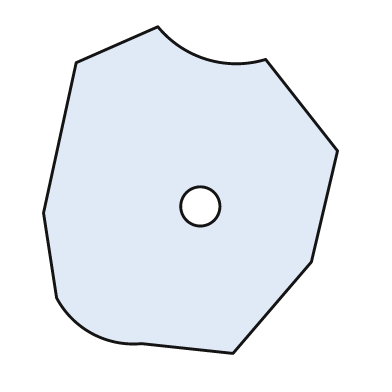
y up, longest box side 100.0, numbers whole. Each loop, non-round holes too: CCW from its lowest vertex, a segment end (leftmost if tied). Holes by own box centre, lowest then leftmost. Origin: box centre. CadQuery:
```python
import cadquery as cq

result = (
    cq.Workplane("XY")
    .moveTo(13.0, -50.0)
    .lineTo(37.0, -22.0)
    .lineTo(45.0, 12.0)
    .lineTo(23.0, 40.0)
    .threePointArc((5.0, 40.0), (-10.0, 50.0))
    .lineTo(-35.0, 39.0)
    .lineTo(-45.0, -7.0)
    .lineTo(-41.0, -33.0)
    .threePointArc((-30.0, -44.0), (-15.0, -47.0))
    .close()
    .moveTo(3.0, -5.0)
    .circle(6.0)
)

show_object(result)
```